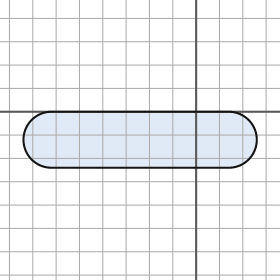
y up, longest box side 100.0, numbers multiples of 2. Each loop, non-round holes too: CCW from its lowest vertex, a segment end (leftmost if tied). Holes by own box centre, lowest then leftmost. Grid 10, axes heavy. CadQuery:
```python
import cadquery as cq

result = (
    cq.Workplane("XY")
    .moveTo(-62.0, -24.0)
    .lineTo(14.0, -24.0)
    .threePointArc((26.0, -12.0), (14.0, 0.0))
    .lineTo(-62.0, 0.0)
    .threePointArc((-74.0, -12.0), (-62.0, -24.0))
    .close()
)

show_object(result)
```